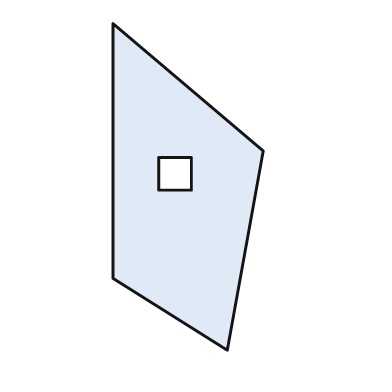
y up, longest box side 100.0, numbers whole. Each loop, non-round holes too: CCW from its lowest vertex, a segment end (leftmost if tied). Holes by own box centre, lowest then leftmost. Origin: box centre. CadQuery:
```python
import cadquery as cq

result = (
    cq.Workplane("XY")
    .moveTo(12.0, -50.0)
    .lineTo(23.0, 11.0)
    .lineTo(-23.0, 50.0)
    .lineTo(-23.0, -28.0)
    .close()
    .moveTo(-9.0, -1.0)
    .lineTo(1.0, -1.0)
    .lineTo(1.0, 9.0)
    .lineTo(-9.0, 9.0)
    .close()
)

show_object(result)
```